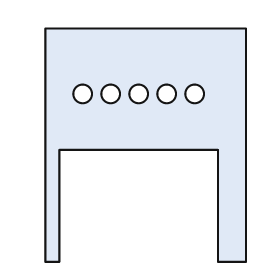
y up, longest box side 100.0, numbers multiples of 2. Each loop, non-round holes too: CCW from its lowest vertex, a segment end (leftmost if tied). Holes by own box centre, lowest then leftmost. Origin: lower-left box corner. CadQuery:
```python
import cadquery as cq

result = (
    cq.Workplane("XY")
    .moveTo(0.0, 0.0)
    .lineTo(6.0, 0.0)
    .lineTo(6.0, 48.0)
    .lineTo(74.0, 48.0)
    .lineTo(74.0, 0.0)
    .lineTo(86.0, 0.0)
    .lineTo(86.0, 100.0)
    .lineTo(0.0, 100.0)
    .close()
    .moveTo(16.0, 72.0)
    .circle(4.0)
    .moveTo(28.0, 72.0)
    .circle(4.0)
    .moveTo(40.0, 72.0)
    .circle(4.0)
    .moveTo(52.0, 72.0)
    .circle(4.0)
    .moveTo(64.0, 72.0)
    .circle(4.0)
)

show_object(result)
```